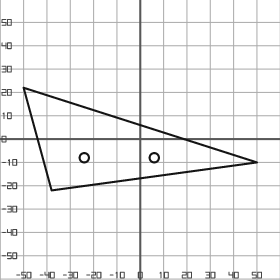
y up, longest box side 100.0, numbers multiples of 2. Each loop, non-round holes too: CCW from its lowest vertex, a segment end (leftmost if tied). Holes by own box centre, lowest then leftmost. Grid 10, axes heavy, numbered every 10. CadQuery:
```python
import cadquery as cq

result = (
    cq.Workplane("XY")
    .moveTo(-38.0, -22.0)
    .lineTo(50.0, -10.0)
    .lineTo(-50.0, 22.0)
    .close()
    .moveTo(-24.0, -8.0)
    .circle(2.0)
    .moveTo(6.0, -8.0)
    .circle(2.0)
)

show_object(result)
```